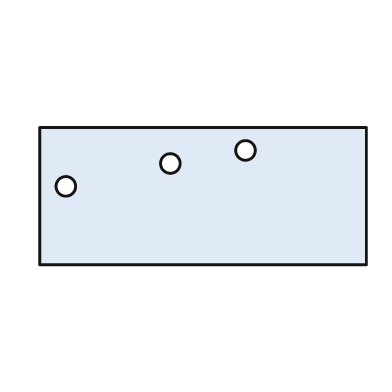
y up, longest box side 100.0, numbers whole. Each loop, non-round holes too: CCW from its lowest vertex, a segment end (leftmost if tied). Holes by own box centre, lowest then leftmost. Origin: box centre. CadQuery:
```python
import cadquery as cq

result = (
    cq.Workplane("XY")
    .moveTo(-50.0, -21.0)
    .lineTo(50.0, -21.0)
    .lineTo(50.0, 21.0)
    .lineTo(-50.0, 21.0)
    .close()
    .moveTo(-42.0, 3.0)
    .circle(3.0)
    .moveTo(-10.0, 10.0)
    .circle(3.0)
    .moveTo(13.0, 14.0)
    .circle(3.0)
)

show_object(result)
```